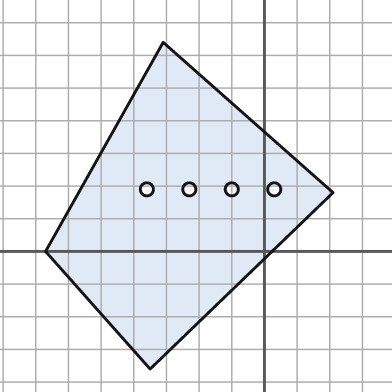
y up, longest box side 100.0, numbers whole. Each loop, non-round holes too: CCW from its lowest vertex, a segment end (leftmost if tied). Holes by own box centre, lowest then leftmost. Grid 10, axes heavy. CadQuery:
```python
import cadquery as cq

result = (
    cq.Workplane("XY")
    .moveTo(-35.0, -36.0)
    .lineTo(21.0, 18.0)
    .lineTo(-31.0, 64.0)
    .lineTo(-67.0, 0.0)
    .close()
    .moveTo(-36.0, 19.0)
    .circle(2.0)
    .moveTo(-23.0, 19.0)
    .circle(2.0)
    .moveTo(-10.0, 19.0)
    .circle(2.0)
    .moveTo(3.0, 19.0)
    .circle(2.0)
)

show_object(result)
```